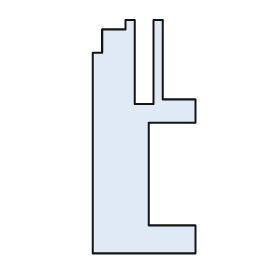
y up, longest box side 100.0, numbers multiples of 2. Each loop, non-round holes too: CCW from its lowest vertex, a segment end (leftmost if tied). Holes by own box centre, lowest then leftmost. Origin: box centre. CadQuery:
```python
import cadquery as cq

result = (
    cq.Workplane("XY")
    .moveTo(-22.0, -50.0)
    .lineTo(22.0, -50.0)
    .lineTo(22.0, -38.0)
    .lineTo(2.0, -38.0)
    .lineTo(2.0, 6.0)
    .lineTo(22.0, 6.0)
    .lineTo(22.0, 16.0)
    .lineTo(8.0, 16.0)
    .lineTo(8.0, 50.0)
    .lineTo(4.0, 50.0)
    .lineTo(4.0, 14.0)
    .lineTo(-4.0, 14.0)
    .lineTo(-4.0, 50.0)
    .lineTo(-8.0, 50.0)
    .lineTo(-8.0, 46.0)
    .lineTo(-18.0, 46.0)
    .lineTo(-18.0, 36.0)
    .lineTo(-22.0, 36.0)
    .close()
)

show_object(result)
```